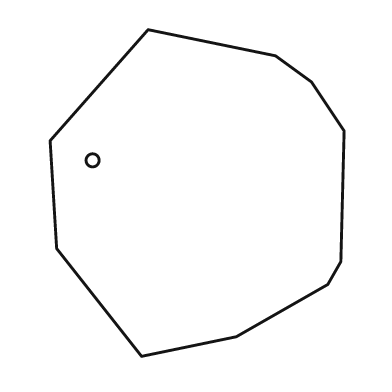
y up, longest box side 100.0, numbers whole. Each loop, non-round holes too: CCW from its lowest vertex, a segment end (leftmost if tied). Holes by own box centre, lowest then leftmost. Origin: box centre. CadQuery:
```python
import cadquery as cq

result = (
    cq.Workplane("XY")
    .moveTo(-17.0, -50.0)
    .lineTo(12.0, -44.0)
    .lineTo(40.0, -28.0)
    .lineTo(44.0, -21.0)
    .lineTo(45.0, 19.0)
    .lineTo(35.0, 34.0)
    .lineTo(24.0, 42.0)
    .lineTo(-15.0, 50.0)
    .lineTo(-45.0, 16.0)
    .lineTo(-43.0, -17.0)
    .close()
    .moveTo(-32.0, 10.0)
    .circle(2.0)
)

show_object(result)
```